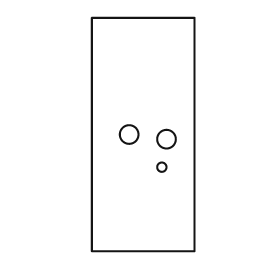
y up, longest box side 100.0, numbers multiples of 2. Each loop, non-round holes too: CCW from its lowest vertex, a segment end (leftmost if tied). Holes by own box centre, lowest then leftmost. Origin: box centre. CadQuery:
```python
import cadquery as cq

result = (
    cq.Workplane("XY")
    .moveTo(-22.0, -50.0)
    .lineTo(22.0, -50.0)
    .lineTo(22.0, 50.0)
    .lineTo(-22.0, 50.0)
    .close()
    .moveTo(8.0, -14.0)
    .circle(2.0)
    .moveTo(10.0, -2.0)
    .circle(4.0)
    .moveTo(-6.0, 0.0)
    .circle(4.0)
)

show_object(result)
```